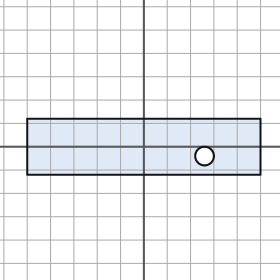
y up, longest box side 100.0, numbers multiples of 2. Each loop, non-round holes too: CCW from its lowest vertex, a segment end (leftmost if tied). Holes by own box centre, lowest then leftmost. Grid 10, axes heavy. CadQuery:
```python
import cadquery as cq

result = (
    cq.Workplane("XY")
    .moveTo(-50.0, -12.0)
    .lineTo(50.0, -12.0)
    .lineTo(50.0, 12.0)
    .lineTo(-50.0, 12.0)
    .close()
    .moveTo(26.0, -4.0)
    .circle(4.0)
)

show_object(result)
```